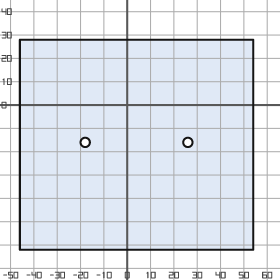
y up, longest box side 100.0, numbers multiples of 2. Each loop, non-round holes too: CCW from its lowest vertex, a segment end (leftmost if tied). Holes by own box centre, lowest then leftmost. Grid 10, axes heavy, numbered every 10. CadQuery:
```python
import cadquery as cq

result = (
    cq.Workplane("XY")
    .moveTo(-46.0, -62.0)
    .lineTo(54.0, -62.0)
    .lineTo(54.0, 28.0)
    .lineTo(-46.0, 28.0)
    .close()
    .moveTo(-18.0, -16.0)
    .circle(2.0)
    .moveTo(26.0, -16.0)
    .circle(2.0)
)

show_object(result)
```